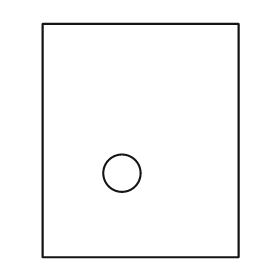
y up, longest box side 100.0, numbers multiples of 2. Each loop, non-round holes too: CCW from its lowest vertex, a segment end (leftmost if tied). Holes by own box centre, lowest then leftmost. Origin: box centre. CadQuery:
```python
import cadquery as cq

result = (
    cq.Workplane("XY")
    .moveTo(-42.0, -50.0)
    .lineTo(42.0, -50.0)
    .lineTo(42.0, 50.0)
    .lineTo(-42.0, 50.0)
    .close()
    .moveTo(-8.0, -14.0)
    .circle(8.0)
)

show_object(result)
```